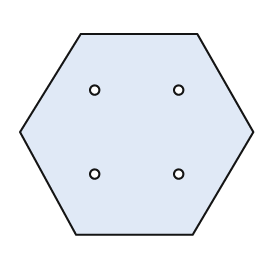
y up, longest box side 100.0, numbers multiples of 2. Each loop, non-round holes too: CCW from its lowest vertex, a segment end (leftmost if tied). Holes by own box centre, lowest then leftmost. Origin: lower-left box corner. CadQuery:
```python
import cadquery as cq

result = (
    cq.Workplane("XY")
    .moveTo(24.0, 0.0)
    .lineTo(74.0, 0.0)
    .lineTo(100.0, 44.0)
    .lineTo(76.0, 86.0)
    .lineTo(26.0, 86.0)
    .lineTo(0.0, 44.0)
    .close()
    .moveTo(32.0, 26.0)
    .circle(2.0)
    .moveTo(68.0, 26.0)
    .circle(2.0)
    .moveTo(32.0, 62.0)
    .circle(2.0)
    .moveTo(68.0, 62.0)
    .circle(2.0)
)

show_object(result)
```